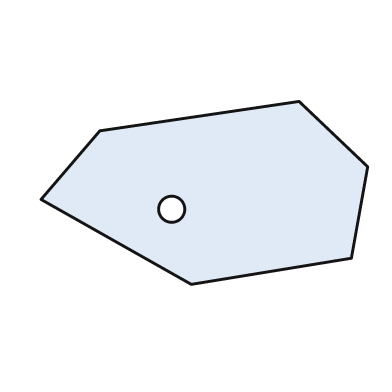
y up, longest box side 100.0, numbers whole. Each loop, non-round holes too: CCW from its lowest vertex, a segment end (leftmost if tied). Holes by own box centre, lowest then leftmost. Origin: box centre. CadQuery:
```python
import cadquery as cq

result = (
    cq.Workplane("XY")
    .moveTo(-4.0, -28.0)
    .lineTo(45.0, -20.0)
    .lineTo(50.0, 8.0)
    .lineTo(29.0, 28.0)
    .lineTo(-32.0, 19.0)
    .lineTo(-50.0, -2.0)
    .close()
    .moveTo(-10.0, -5.0)
    .circle(4.0)
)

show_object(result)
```